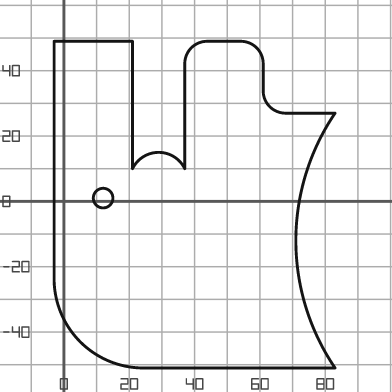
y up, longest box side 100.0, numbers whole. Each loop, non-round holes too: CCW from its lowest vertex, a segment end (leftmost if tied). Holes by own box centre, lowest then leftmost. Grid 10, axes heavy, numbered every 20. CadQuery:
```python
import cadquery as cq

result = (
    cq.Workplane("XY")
    .moveTo(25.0, -51.0)
    .lineTo(83.0, -51.0)
    .threePointArc((71.0, -12.0), (83.0, 27.0))
    .lineTo(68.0, 27.0)
    .threePointArc((63.0, 29.0), (61.0, 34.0))
    .lineTo(61.0, 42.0)
    .threePointArc((59.0, 47.0), (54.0, 49.0))
    .lineTo(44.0, 49.0)
    .threePointArc((39.0, 47.0), (37.0, 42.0))
    .lineTo(37.0, 10.0)
    .threePointArc((29.0, 15.0), (21.0, 10.0))
    .lineTo(21.0, 49.0)
    .lineTo(-3.0, 49.0)
    .lineTo(-3.0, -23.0)
    .threePointArc((5.0, -43.0), (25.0, -51.0))
    .close()
    .moveTo(12.0, 1.0)
    .circle(3.0)
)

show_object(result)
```